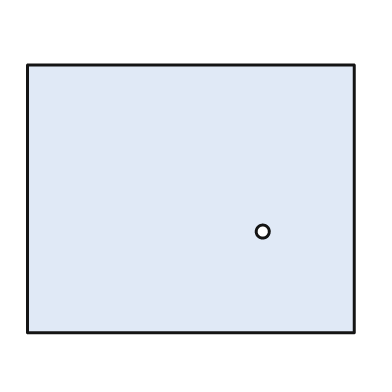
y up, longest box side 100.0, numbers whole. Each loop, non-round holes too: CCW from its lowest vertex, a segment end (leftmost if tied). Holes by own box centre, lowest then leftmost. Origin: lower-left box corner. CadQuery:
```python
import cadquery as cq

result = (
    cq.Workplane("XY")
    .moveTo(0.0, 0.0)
    .lineTo(100.0, 0.0)
    .lineTo(100.0, 82.0)
    .lineTo(0.0, 82.0)
    .close()
    .moveTo(72.0, 31.0)
    .circle(2.0)
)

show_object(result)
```